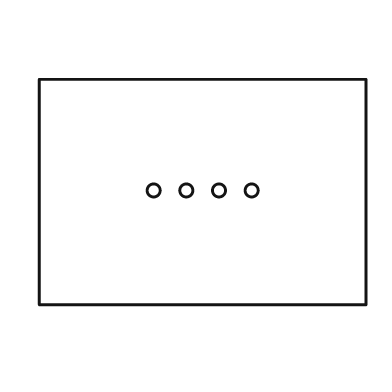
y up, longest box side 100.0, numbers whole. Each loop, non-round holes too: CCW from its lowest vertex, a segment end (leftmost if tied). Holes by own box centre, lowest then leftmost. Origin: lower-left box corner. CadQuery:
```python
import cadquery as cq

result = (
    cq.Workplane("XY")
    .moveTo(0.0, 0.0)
    .lineTo(100.0, 0.0)
    .lineTo(100.0, 69.0)
    .lineTo(0.0, 69.0)
    .close()
    .moveTo(35.0, 35.0)
    .circle(2.0)
    .moveTo(45.0, 35.0)
    .circle(2.0)
    .moveTo(55.0, 35.0)
    .circle(2.0)
    .moveTo(65.0, 35.0)
    .circle(2.0)
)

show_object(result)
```